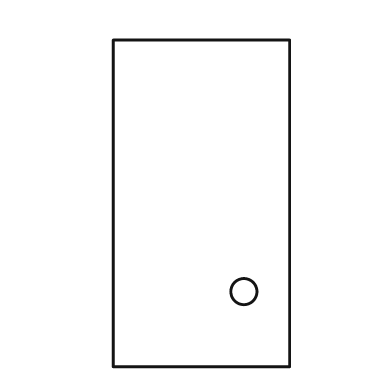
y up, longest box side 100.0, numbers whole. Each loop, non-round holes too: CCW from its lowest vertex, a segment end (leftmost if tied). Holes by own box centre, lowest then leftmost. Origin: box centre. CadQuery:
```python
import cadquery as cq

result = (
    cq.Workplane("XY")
    .moveTo(-27.0, -50.0)
    .lineTo(27.0, -50.0)
    .lineTo(27.0, 50.0)
    .lineTo(-27.0, 50.0)
    .close()
    .moveTo(13.0, -27.0)
    .circle(4.0)
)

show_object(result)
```